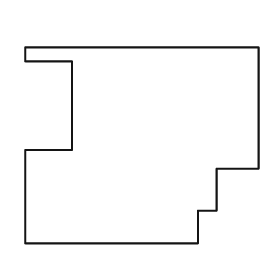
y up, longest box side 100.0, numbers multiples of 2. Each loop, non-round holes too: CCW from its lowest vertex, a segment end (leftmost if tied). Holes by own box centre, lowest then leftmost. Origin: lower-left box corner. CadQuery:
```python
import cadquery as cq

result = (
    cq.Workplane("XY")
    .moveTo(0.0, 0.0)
    .lineTo(74.0, 0.0)
    .lineTo(74.0, 14.0)
    .lineTo(82.0, 14.0)
    .lineTo(82.0, 32.0)
    .lineTo(100.0, 32.0)
    .lineTo(100.0, 84.0)
    .lineTo(0.0, 84.0)
    .lineTo(0.0, 78.0)
    .lineTo(20.0, 78.0)
    .lineTo(20.0, 40.0)
    .lineTo(0.0, 40.0)
    .close()
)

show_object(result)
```